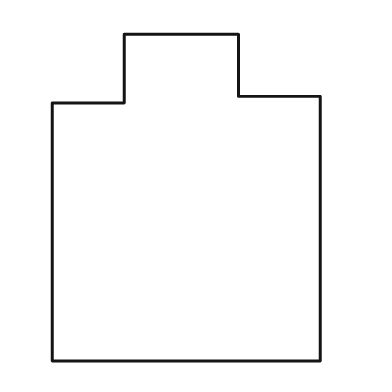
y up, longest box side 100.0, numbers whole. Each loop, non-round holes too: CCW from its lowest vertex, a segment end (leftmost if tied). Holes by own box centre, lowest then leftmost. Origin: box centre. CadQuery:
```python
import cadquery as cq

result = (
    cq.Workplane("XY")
    .moveTo(-41.0, -50.0)
    .lineTo(41.0, -50.0)
    .lineTo(41.0, 31.0)
    .lineTo(16.0, 31.0)
    .lineTo(16.0, 50.0)
    .lineTo(-19.0, 50.0)
    .lineTo(-19.0, 29.0)
    .lineTo(-41.0, 29.0)
    .close()
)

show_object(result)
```